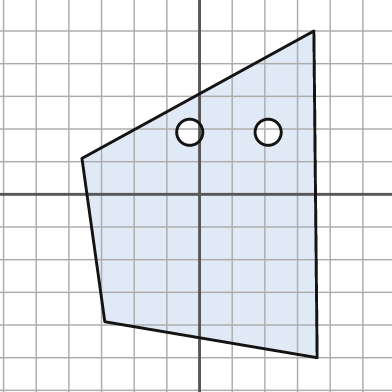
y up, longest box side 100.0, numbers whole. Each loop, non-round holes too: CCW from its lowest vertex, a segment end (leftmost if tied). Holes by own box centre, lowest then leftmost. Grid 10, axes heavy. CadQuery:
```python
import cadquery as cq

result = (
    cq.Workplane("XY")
    .moveTo(36.0, -50.0)
    .lineTo(35.0, 50.0)
    .lineTo(-36.0, 11.0)
    .lineTo(-29.0, -39.0)
    .close()
    .moveTo(-3.0, 19.0)
    .circle(4.0)
    .moveTo(21.0, 19.0)
    .circle(4.0)
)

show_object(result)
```